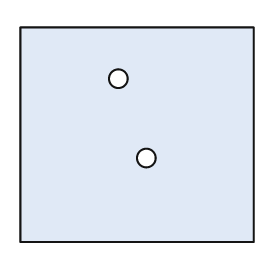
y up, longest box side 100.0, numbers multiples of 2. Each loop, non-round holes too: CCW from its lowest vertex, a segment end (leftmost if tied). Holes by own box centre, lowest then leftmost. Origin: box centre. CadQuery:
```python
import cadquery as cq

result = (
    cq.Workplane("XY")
    .moveTo(-50.0, -46.0)
    .lineTo(50.0, -46.0)
    .lineTo(50.0, 46.0)
    .lineTo(-50.0, 46.0)
    .close()
    .moveTo(4.0, -10.0)
    .circle(4.0)
    .moveTo(-8.0, 24.0)
    .circle(4.0)
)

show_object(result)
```